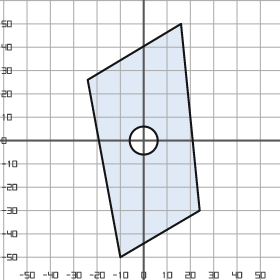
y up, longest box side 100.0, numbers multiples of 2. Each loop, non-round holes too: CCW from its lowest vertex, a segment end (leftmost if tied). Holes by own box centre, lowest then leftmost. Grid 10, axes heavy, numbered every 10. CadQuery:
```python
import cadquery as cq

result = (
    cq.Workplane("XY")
    .moveTo(-10.0, -50.0)
    .lineTo(24.0, -30.0)
    .lineTo(16.0, 50.0)
    .lineTo(-24.0, 26.0)
    .close()
    .moveTo(0.0, 0.0)
    .circle(6.0)
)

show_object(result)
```